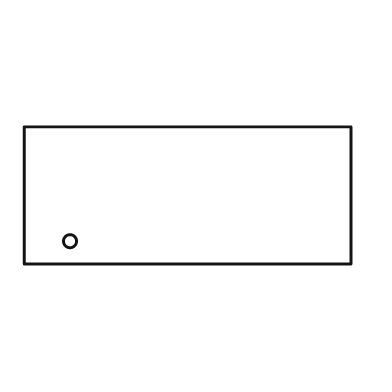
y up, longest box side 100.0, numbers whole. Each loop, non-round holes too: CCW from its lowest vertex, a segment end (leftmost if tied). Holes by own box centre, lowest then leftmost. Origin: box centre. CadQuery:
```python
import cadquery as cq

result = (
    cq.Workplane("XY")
    .moveTo(-50.0, -21.0)
    .lineTo(50.0, -21.0)
    .lineTo(50.0, 21.0)
    .lineTo(-50.0, 21.0)
    .close()
    .moveTo(-36.0, -14.0)
    .circle(2.0)
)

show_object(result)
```